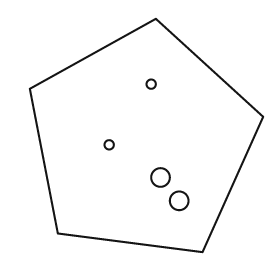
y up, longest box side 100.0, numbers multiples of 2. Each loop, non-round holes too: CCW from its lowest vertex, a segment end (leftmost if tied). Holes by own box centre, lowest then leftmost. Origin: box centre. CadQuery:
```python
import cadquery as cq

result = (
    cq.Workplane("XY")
    .moveTo(24.0, -50.0)
    .lineTo(50.0, 8.0)
    .lineTo(4.0, 50.0)
    .lineTo(-50.0, 20.0)
    .lineTo(-38.0, -42.0)
    .close()
    .moveTo(14.0, -28.0)
    .circle(4.0)
    .moveTo(6.0, -18.0)
    .circle(4.0)
    .moveTo(-16.0, -4.0)
    .circle(2.0)
    .moveTo(2.0, 22.0)
    .circle(2.0)
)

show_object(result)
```